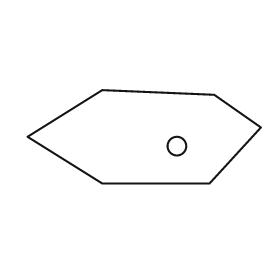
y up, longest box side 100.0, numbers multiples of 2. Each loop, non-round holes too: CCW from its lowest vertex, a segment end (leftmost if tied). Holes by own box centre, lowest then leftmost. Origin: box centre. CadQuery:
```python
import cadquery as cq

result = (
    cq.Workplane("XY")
    .moveTo(-18.0, -20.0)
    .lineTo(28.0, -20.0)
    .lineTo(50.0, 4.0)
    .lineTo(30.0, 18.0)
    .lineTo(-18.0, 20.0)
    .lineTo(-50.0, 0.0)
    .close()
    .moveTo(14.0, -4.0)
    .circle(4.0)
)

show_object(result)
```